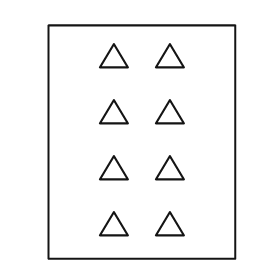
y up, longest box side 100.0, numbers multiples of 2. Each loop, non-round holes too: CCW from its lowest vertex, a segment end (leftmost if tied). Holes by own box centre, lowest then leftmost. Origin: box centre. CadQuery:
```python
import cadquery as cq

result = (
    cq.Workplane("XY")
    .moveTo(-40.0, -50.0)
    .lineTo(40.0, -50.0)
    .lineTo(40.0, 50.0)
    .lineTo(-40.0, 50.0)
    .close()
    .moveTo(-18.0, -40.0)
    .lineTo(-6.0, -40.0)
    .lineTo(-12.0, -30.0)
    .close()
    .moveTo(6.0, -40.0)
    .lineTo(18.0, -40.0)
    .lineTo(12.0, -30.0)
    .close()
    .moveTo(-18.0, -16.0)
    .lineTo(-6.0, -16.0)
    .lineTo(-12.0, -6.0)
    .close()
    .moveTo(6.0, -16.0)
    .lineTo(18.0, -16.0)
    .lineTo(12.0, -6.0)
    .close()
    .moveTo(-18.0, 8.0)
    .lineTo(-6.0, 8.0)
    .lineTo(-12.0, 18.0)
    .close()
    .moveTo(6.0, 8.0)
    .lineTo(18.0, 8.0)
    .lineTo(12.0, 18.0)
    .close()
    .moveTo(-18.0, 32.0)
    .lineTo(-6.0, 32.0)
    .lineTo(-12.0, 42.0)
    .close()
    .moveTo(6.0, 32.0)
    .lineTo(18.0, 32.0)
    .lineTo(12.0, 42.0)
    .close()
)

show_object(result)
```